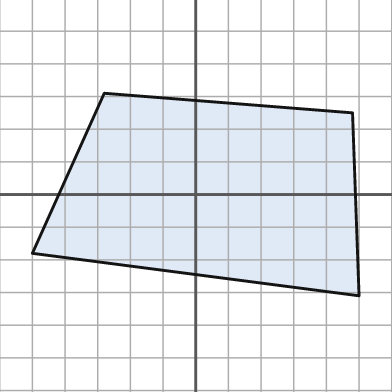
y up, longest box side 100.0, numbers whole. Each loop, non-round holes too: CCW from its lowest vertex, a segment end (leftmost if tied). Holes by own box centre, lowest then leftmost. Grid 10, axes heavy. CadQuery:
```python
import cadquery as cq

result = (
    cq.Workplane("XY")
    .moveTo(50.0, -31.0)
    .lineTo(48.0, 25.0)
    .lineTo(-28.0, 31.0)
    .lineTo(-50.0, -18.0)
    .close()
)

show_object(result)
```